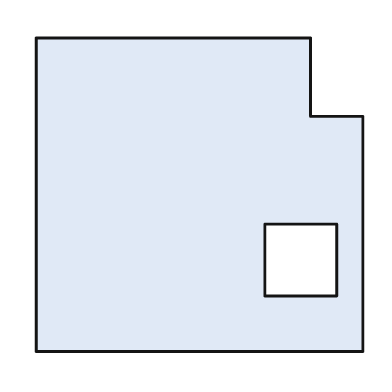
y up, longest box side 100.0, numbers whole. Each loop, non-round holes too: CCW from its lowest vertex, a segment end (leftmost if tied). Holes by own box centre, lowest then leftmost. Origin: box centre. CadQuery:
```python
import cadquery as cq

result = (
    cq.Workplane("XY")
    .moveTo(-50.0, -48.0)
    .lineTo(50.0, -48.0)
    .lineTo(50.0, 24.0)
    .lineTo(34.0, 24.0)
    .lineTo(34.0, 48.0)
    .lineTo(-50.0, 48.0)
    .close()
    .moveTo(20.0, -31.0)
    .lineTo(42.0, -31.0)
    .lineTo(42.0, -9.0)
    .lineTo(20.0, -9.0)
    .close()
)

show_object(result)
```